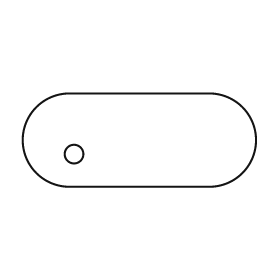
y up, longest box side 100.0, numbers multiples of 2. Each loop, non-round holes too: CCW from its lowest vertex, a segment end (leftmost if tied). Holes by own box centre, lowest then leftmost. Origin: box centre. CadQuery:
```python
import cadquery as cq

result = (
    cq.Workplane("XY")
    .moveTo(-30.0, -20.0)
    .lineTo(30.0, -20.0)
    .threePointArc((50.0, 0.0), (30.0, 20.0))
    .lineTo(-30.0, 20.0)
    .threePointArc((-50.0, 0.0), (-30.0, -20.0))
    .close()
    .moveTo(-28.0, -6.0)
    .circle(4.0)
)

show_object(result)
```